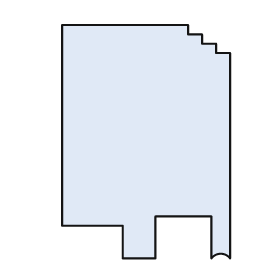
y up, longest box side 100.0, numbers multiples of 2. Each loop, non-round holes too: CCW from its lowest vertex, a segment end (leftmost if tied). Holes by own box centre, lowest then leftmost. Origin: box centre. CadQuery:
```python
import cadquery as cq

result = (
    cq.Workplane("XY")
    .moveTo(-10.0, -50.0)
    .lineTo(4.0, -50.0)
    .lineTo(4.0, -32.0)
    .lineTo(28.0, -32.0)
    .lineTo(28.0, -50.0)
    .threePointArc((32.0, -48.0), (36.0, -50.0))
    .lineTo(36.0, 38.0)
    .lineTo(30.0, 38.0)
    .lineTo(30.0, 42.0)
    .lineTo(24.0, 42.0)
    .lineTo(24.0, 46.0)
    .lineTo(18.0, 46.0)
    .lineTo(18.0, 50.0)
    .lineTo(-36.0, 50.0)
    .lineTo(-36.0, -36.0)
    .lineTo(-10.0, -36.0)
    .close()
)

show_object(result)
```